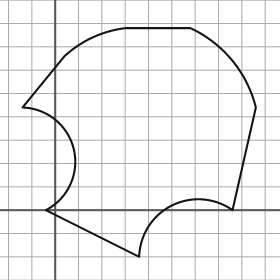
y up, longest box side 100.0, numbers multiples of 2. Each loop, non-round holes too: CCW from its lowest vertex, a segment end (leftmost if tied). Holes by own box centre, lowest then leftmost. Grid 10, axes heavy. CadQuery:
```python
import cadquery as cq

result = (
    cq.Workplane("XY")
    .moveTo(36.0, -20.0)
    .threePointArc((50.0, 2.0), (76.0, 0.0))
    .lineTo(86.0, 44.0)
    .threePointArc((76.0, 64.0), (58.0, 78.0))
    .lineTo(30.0, 78.0)
    .threePointArc((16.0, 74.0), (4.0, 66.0))
    .lineTo(-14.0, 44.0)
    .threePointArc((8.0, 26.0), (-4.0, 0.0))
    .close()
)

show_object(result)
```